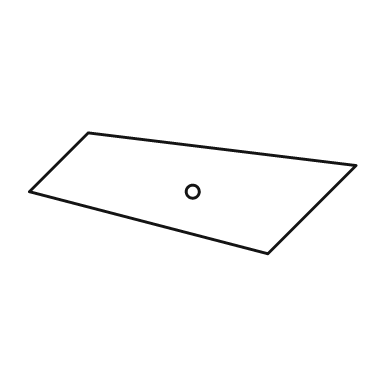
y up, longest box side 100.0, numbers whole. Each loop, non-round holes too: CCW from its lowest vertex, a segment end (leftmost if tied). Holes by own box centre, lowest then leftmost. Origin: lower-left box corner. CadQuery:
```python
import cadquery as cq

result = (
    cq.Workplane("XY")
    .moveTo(73.0, 0.0)
    .lineTo(100.0, 27.0)
    .lineTo(18.0, 37.0)
    .lineTo(0.0, 19.0)
    .close()
    .moveTo(50.0, 19.0)
    .circle(2.0)
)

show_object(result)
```